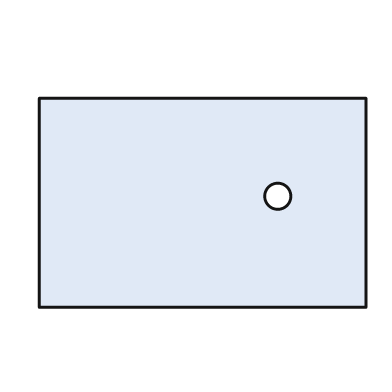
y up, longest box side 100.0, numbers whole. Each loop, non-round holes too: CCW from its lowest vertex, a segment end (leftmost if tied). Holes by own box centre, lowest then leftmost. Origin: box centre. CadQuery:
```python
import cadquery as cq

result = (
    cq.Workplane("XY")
    .moveTo(-50.0, -32.0)
    .lineTo(50.0, -32.0)
    .lineTo(50.0, 32.0)
    .lineTo(-50.0, 32.0)
    .close()
    .moveTo(23.0, 2.0)
    .circle(4.0)
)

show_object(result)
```